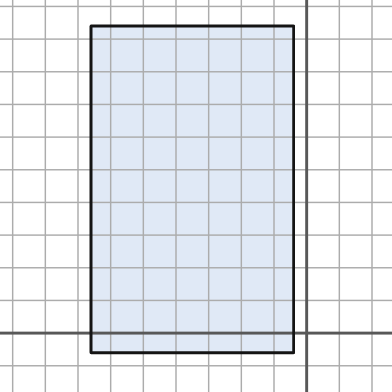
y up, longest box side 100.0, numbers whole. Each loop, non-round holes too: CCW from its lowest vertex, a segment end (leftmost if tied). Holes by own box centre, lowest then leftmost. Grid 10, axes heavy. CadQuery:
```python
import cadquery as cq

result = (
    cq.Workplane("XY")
    .moveTo(-66.0, -6.0)
    .lineTo(-4.0, -6.0)
    .lineTo(-4.0, 94.0)
    .lineTo(-66.0, 94.0)
    .close()
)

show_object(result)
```